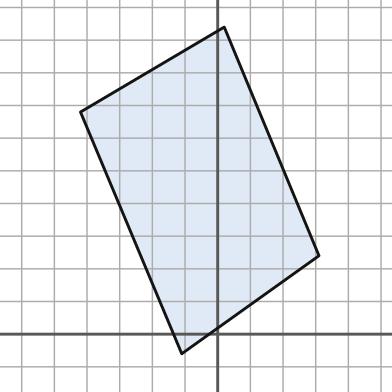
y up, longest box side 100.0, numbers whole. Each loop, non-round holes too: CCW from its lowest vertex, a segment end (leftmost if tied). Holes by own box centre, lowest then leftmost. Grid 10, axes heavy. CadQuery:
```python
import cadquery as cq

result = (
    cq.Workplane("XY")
    .moveTo(-11.0, -6.0)
    .lineTo(31.0, 24.0)
    .lineTo(2.0, 94.0)
    .lineTo(-42.0, 68.0)
    .close()
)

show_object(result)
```